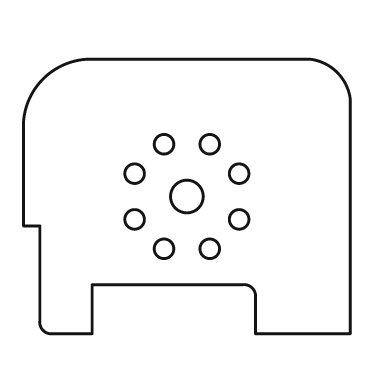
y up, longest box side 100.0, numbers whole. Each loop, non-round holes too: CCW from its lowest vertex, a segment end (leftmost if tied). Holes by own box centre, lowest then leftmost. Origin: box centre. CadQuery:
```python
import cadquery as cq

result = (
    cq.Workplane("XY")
    .moveTo(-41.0, -42.0)
    .lineTo(-29.0, -42.0)
    .lineTo(-29.0, -27.0)
    .lineTo(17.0, -27.0)
    .threePointArc((20.0, -28.0), (21.0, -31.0))
    .lineTo(21.0, -42.0)
    .lineTo(50.0, -42.0)
    .lineTo(50.0, 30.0)
    .threePointArc((46.0, 38.0), (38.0, 42.0))
    .lineTo(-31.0, 42.0)
    .threePointArc((-44.0, 36.0), (-50.0, 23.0))
    .lineTo(-50.0, -9.0)
    .lineTo(-45.0, -9.0)
    .lineTo(-45.0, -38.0)
    .threePointArc((-44.0, -41.0), (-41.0, -42.0))
    .close()
    .moveTo(-7.0, -16.0)
    .circle(3.0)
    .moveTo(7.0, -16.0)
    .circle(3.0)
    .moveTo(-16.0, -7.0)
    .circle(3.0)
    .moveTo(16.0, -7.0)
    .circle(3.0)
    .moveTo(0.0, 0.0)
    .circle(5.0)
    .moveTo(-16.0, 7.0)
    .circle(3.0)
    .moveTo(16.0, 7.0)
    .circle(3.0)
    .moveTo(-7.0, 16.0)
    .circle(3.0)
    .moveTo(7.0, 16.0)
    .circle(3.0)
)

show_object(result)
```